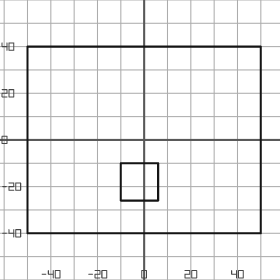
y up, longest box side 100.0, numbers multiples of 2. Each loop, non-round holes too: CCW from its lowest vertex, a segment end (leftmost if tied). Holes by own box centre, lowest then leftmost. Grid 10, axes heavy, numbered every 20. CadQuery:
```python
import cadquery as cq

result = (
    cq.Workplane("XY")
    .moveTo(-50.0, -40.0)
    .lineTo(50.0, -40.0)
    .lineTo(50.0, 40.0)
    .lineTo(-50.0, 40.0)
    .close()
    .moveTo(-10.0, -26.0)
    .lineTo(6.0, -26.0)
    .lineTo(6.0, -10.0)
    .lineTo(-10.0, -10.0)
    .close()
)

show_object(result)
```